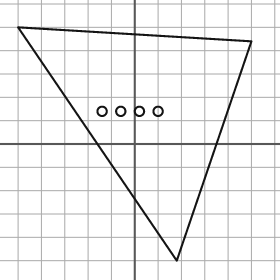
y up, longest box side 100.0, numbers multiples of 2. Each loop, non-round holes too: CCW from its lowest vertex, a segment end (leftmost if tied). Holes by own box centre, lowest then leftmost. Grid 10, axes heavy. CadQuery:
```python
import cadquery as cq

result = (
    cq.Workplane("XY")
    .moveTo(18.0, -50.0)
    .lineTo(50.0, 44.0)
    .lineTo(-50.0, 50.0)
    .close()
    .moveTo(-14.0, 14.0)
    .circle(2.0)
    .moveTo(-6.0, 14.0)
    .circle(2.0)
    .moveTo(2.0, 14.0)
    .circle(2.0)
    .moveTo(10.0, 14.0)
    .circle(2.0)
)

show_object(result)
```